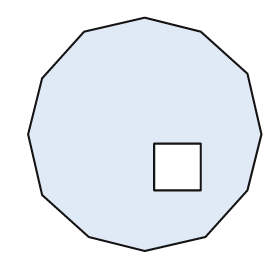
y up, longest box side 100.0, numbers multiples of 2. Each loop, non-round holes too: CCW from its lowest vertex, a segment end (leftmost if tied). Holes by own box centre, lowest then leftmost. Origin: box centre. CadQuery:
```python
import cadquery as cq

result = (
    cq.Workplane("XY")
    .moveTo(0.0, -50.0)
    .lineTo(26.0, -44.0)
    .lineTo(44.0, -24.0)
    .lineTo(50.0, 0.0)
    .lineTo(44.0, 26.0)
    .lineTo(24.0, 44.0)
    .lineTo(0.0, 50.0)
    .lineTo(-26.0, 44.0)
    .lineTo(-44.0, 24.0)
    .lineTo(-50.0, 0.0)
    .lineTo(-44.0, -26.0)
    .lineTo(-24.0, -44.0)
    .close()
    .moveTo(4.0, -24.0)
    .lineTo(24.0, -24.0)
    .lineTo(24.0, -4.0)
    .lineTo(4.0, -4.0)
    .close()
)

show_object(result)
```